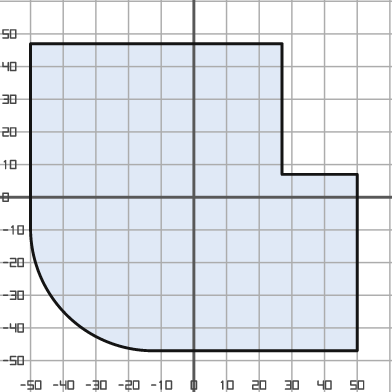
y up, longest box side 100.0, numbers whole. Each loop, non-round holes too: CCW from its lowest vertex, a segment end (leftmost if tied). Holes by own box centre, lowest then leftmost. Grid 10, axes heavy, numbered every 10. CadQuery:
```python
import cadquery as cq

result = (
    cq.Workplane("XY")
    .moveTo(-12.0, -47.0)
    .lineTo(50.0, -47.0)
    .lineTo(50.0, 7.0)
    .lineTo(27.0, 7.0)
    .lineTo(27.0, 47.0)
    .lineTo(-50.0, 47.0)
    .lineTo(-50.0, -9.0)
    .threePointArc((-39.0, -36.0), (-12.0, -47.0))
    .close()
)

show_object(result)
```